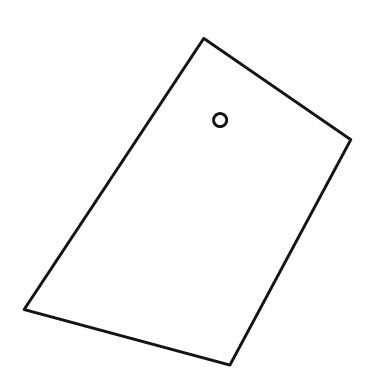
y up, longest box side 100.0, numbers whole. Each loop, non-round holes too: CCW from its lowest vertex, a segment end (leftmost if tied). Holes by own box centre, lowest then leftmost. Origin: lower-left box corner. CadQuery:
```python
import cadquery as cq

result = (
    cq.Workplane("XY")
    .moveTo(63.0, 0.0)
    .lineTo(100.0, 69.0)
    .lineTo(55.0, 100.0)
    .lineTo(0.0, 17.0)
    .close()
    .moveTo(60.0, 75.0)
    .circle(2.0)
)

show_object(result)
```